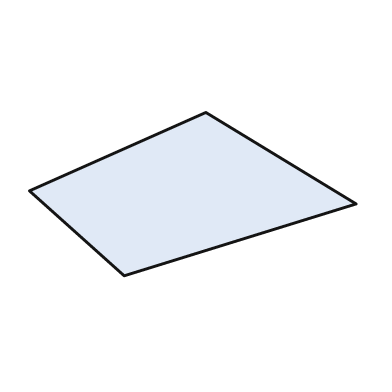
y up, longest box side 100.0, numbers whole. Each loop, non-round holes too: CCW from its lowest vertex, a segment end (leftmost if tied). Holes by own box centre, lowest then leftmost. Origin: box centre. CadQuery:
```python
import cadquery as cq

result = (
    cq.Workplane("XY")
    .moveTo(-21.0, -25.0)
    .lineTo(50.0, -3.0)
    .lineTo(4.0, 25.0)
    .lineTo(-50.0, 1.0)
    .close()
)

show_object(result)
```